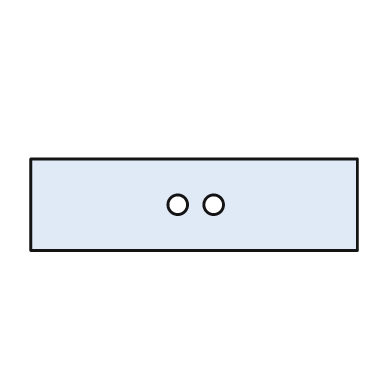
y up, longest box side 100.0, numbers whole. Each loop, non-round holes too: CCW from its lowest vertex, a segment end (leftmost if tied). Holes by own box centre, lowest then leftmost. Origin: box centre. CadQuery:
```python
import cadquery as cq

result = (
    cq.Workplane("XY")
    .moveTo(-50.0, -14.0)
    .lineTo(50.0, -14.0)
    .lineTo(50.0, 14.0)
    .lineTo(-50.0, 14.0)
    .close()
    .moveTo(-5.0, 0.0)
    .circle(3.0)
    .moveTo(6.0, 0.0)
    .circle(3.0)
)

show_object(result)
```